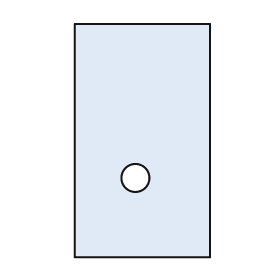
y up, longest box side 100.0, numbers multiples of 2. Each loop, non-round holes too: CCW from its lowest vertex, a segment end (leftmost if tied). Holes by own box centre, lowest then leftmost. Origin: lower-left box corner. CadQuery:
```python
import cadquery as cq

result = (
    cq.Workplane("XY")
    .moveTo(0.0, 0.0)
    .lineTo(58.0, 0.0)
    .lineTo(58.0, 100.0)
    .lineTo(0.0, 100.0)
    .close()
    .moveTo(26.0, 34.0)
    .circle(6.0)
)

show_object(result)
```